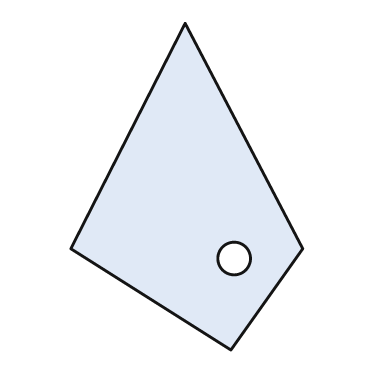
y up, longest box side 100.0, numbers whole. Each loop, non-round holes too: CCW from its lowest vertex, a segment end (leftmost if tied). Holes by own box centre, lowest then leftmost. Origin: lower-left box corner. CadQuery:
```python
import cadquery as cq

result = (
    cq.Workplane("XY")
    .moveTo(49.0, 0.0)
    .lineTo(71.0, 31.0)
    .lineTo(35.0, 100.0)
    .lineTo(0.0, 31.0)
    .close()
    .moveTo(50.0, 28.0)
    .circle(5.0)
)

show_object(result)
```